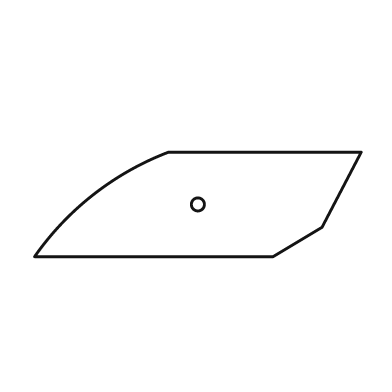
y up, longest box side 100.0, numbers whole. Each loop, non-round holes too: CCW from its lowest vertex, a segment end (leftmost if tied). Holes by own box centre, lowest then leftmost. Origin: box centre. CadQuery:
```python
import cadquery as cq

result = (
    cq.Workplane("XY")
    .moveTo(-50.0, -16.0)
    .lineTo(23.0, -16.0)
    .lineTo(38.0, -7.0)
    .lineTo(50.0, 16.0)
    .lineTo(-9.0, 16.0)
    .threePointArc((-32.0, 3.0), (-50.0, -16.0))
    .close()
    .moveTo(0.0, 0.0)
    .circle(2.0)
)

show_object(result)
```